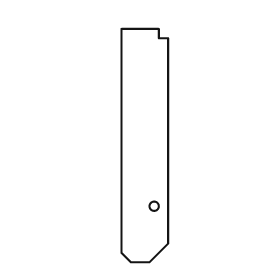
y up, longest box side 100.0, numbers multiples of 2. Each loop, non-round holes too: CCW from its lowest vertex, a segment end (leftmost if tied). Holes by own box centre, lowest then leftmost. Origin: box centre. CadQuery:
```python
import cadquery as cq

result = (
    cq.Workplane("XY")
    .moveTo(-6.0, -50.0)
    .lineTo(2.0, -50.0)
    .lineTo(10.0, -42.0)
    .lineTo(10.0, 46.0)
    .lineTo(6.0, 46.0)
    .lineTo(6.0, 50.0)
    .lineTo(-10.0, 50.0)
    .lineTo(-10.0, -46.0)
    .close()
    .moveTo(4.0, -26.0)
    .circle(2.0)
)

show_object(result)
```